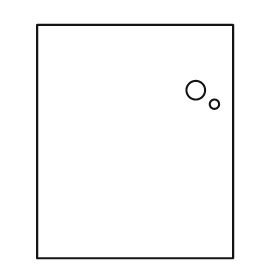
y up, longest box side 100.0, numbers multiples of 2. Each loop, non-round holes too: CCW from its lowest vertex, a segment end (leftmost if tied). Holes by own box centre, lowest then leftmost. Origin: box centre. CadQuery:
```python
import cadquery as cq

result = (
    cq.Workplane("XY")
    .moveTo(-42.0, -50.0)
    .lineTo(42.0, -50.0)
    .lineTo(42.0, 50.0)
    .lineTo(-42.0, 50.0)
    .close()
    .moveTo(34.0, 16.0)
    .circle(2.0)
    .moveTo(26.0, 22.0)
    .circle(4.0)
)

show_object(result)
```